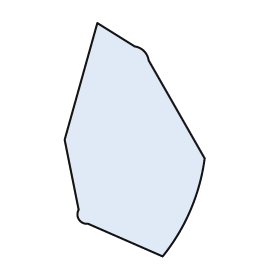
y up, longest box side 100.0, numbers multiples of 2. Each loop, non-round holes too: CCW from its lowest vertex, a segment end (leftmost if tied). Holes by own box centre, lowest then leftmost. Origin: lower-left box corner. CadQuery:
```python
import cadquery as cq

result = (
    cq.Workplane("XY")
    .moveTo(42.0, 0.0)
    .threePointArc((54.0, 20.0), (60.0, 42.0))
    .lineTo(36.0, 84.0)
    .threePointArc((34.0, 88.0), (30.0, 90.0))
    .lineTo(14.0, 100.0)
    .lineTo(0.0, 50.0)
    .lineTo(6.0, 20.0)
    .threePointArc((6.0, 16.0), (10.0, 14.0))
    .close()
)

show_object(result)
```